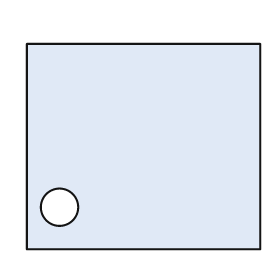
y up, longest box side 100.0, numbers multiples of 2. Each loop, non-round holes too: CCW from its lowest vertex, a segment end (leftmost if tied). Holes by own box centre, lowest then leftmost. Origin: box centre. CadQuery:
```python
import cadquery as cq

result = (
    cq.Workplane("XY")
    .moveTo(-50.0, -44.0)
    .lineTo(50.0, -44.0)
    .lineTo(50.0, 44.0)
    .lineTo(-50.0, 44.0)
    .close()
    .moveTo(-36.0, -26.0)
    .circle(8.0)
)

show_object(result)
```